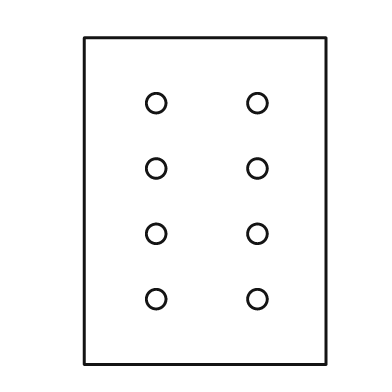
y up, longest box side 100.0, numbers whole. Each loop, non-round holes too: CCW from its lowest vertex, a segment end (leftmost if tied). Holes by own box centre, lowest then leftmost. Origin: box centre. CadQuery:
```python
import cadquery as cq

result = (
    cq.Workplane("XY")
    .moveTo(-37.0, -50.0)
    .lineTo(37.0, -50.0)
    .lineTo(37.0, 50.0)
    .lineTo(-37.0, 50.0)
    .close()
    .moveTo(-15.0, -30.0)
    .circle(3.0)
    .moveTo(16.0, -30.0)
    .circle(3.0)
    .moveTo(-15.0, -10.0)
    .circle(3.0)
    .moveTo(16.0, -10.0)
    .circle(3.0)
    .moveTo(-15.0, 10.0)
    .circle(3.0)
    .moveTo(16.0, 10.0)
    .circle(3.0)
    .moveTo(-15.0, 30.0)
    .circle(3.0)
    .moveTo(16.0, 30.0)
    .circle(3.0)
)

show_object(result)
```